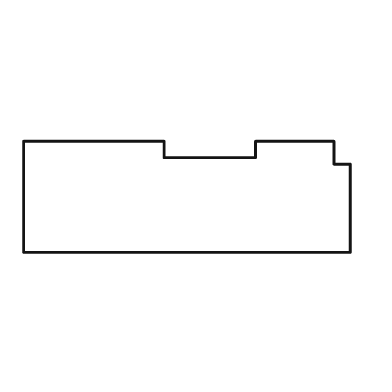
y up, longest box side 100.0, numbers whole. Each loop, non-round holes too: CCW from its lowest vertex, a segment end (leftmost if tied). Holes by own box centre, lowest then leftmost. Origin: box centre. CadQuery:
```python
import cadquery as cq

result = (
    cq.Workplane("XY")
    .moveTo(-50.0, -17.0)
    .lineTo(50.0, -17.0)
    .lineTo(50.0, 10.0)
    .lineTo(45.0, 10.0)
    .lineTo(45.0, 17.0)
    .lineTo(21.0, 17.0)
    .lineTo(21.0, 12.0)
    .lineTo(-7.0, 12.0)
    .lineTo(-7.0, 17.0)
    .lineTo(-50.0, 17.0)
    .close()
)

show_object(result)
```